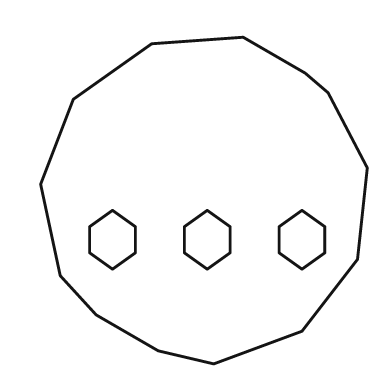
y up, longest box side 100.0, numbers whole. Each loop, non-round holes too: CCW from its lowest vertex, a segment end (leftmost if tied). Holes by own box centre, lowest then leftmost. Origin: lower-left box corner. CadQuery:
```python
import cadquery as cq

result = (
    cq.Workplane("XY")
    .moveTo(53.0, 0.0)
    .lineTo(80.0, 10.0)
    .lineTo(97.0, 32.0)
    .lineTo(100.0, 60.0)
    .lineTo(88.0, 83.0)
    .lineTo(81.0, 89.0)
    .lineTo(62.0, 100.0)
    .lineTo(34.0, 98.0)
    .lineTo(10.0, 81.0)
    .lineTo(0.0, 55.0)
    .lineTo(6.0, 27.0)
    .lineTo(17.0, 15.0)
    .lineTo(36.0, 4.0)
    .close()
    .moveTo(22.0, 29.0)
    .lineTo(29.0, 34.0)
    .lineTo(29.0, 42.0)
    .lineTo(22.0, 47.0)
    .lineTo(15.0, 42.0)
    .lineTo(15.0, 34.0)
    .close()
    .moveTo(51.0, 29.0)
    .lineTo(58.0, 34.0)
    .lineTo(58.0, 42.0)
    .lineTo(51.0, 47.0)
    .lineTo(44.0, 42.0)
    .lineTo(44.0, 34.0)
    .close()
    .moveTo(80.0, 29.0)
    .lineTo(87.0, 34.0)
    .lineTo(87.0, 42.0)
    .lineTo(80.0, 47.0)
    .lineTo(73.0, 42.0)
    .lineTo(73.0, 34.0)
    .close()
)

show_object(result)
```